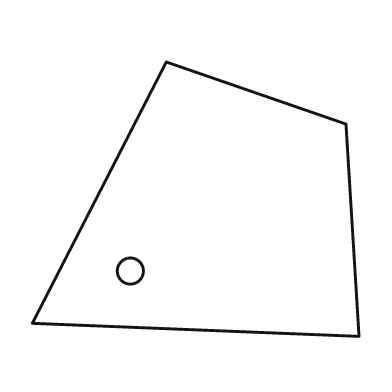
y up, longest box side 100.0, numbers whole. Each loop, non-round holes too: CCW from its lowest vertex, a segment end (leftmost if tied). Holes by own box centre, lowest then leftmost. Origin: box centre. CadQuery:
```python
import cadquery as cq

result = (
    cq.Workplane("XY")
    .moveTo(50.0, -42.0)
    .lineTo(46.0, 23.0)
    .lineTo(-9.0, 42.0)
    .lineTo(-50.0, -38.0)
    .close()
    .moveTo(-20.0, -22.0)
    .circle(4.0)
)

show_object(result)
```